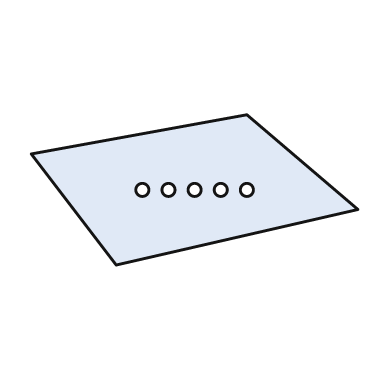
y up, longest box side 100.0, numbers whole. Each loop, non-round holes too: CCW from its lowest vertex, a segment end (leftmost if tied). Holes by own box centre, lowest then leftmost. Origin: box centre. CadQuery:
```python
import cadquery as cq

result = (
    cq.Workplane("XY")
    .moveTo(-24.0, -23.0)
    .lineTo(50.0, -6.0)
    .lineTo(16.0, 23.0)
    .lineTo(-50.0, 11.0)
    .close()
    .moveTo(-16.0, 0.0)
    .circle(2.0)
    .moveTo(-8.0, 0.0)
    .circle(2.0)
    .moveTo(0.0, 0.0)
    .circle(2.0)
    .moveTo(8.0, 0.0)
    .circle(2.0)
    .moveTo(16.0, 0.0)
    .circle(2.0)
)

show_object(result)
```